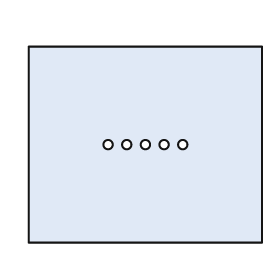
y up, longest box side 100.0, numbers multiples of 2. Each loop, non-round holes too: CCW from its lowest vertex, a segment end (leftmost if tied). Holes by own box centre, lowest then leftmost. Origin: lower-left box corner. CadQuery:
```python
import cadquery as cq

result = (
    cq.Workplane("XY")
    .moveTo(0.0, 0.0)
    .lineTo(100.0, 0.0)
    .lineTo(100.0, 84.0)
    .lineTo(0.0, 84.0)
    .close()
    .moveTo(34.0, 42.0)
    .circle(2.0)
    .moveTo(42.0, 42.0)
    .circle(2.0)
    .moveTo(50.0, 42.0)
    .circle(2.0)
    .moveTo(58.0, 42.0)
    .circle(2.0)
    .moveTo(66.0, 42.0)
    .circle(2.0)
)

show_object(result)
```